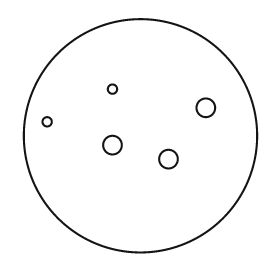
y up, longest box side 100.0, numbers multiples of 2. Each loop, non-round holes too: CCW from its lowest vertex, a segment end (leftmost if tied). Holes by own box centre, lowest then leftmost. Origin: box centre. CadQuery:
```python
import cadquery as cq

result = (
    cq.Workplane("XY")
    .moveTo(0.0, 0.0)
    .circle(50.0)
    .moveTo(12.0, -10.0)
    .circle(4.0)
    .moveTo(-12.0, -4.0)
    .circle(4.0)
    .moveTo(-40.0, 6.0)
    .circle(2.0)
    .moveTo(28.0, 12.0)
    .circle(4.0)
    .moveTo(-12.0, 20.0)
    .circle(2.0)
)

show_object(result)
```